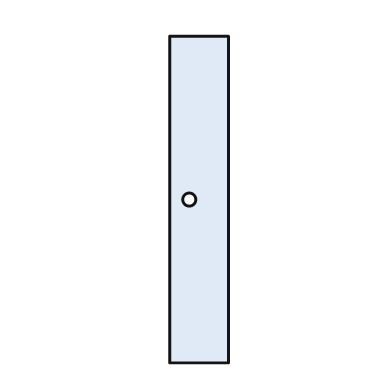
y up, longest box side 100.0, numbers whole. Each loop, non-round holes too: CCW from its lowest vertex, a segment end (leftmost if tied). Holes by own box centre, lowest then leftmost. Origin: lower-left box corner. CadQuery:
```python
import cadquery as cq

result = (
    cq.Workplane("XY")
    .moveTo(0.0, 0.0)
    .lineTo(18.0, 0.0)
    .lineTo(18.0, 100.0)
    .lineTo(0.0, 100.0)
    .close()
    .moveTo(6.0, 50.0)
    .circle(2.0)
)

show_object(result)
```